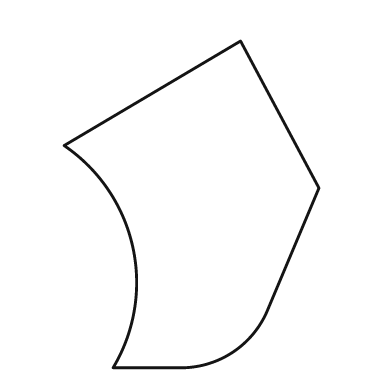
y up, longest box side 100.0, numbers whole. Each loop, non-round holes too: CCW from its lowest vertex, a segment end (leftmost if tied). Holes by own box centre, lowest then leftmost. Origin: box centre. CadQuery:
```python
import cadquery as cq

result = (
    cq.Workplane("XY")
    .moveTo(-24.0, -50.0)
    .lineTo(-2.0, -50.0)
    .threePointArc((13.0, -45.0), (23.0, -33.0))
    .lineTo(39.0, 5.0)
    .lineTo(15.0, 50.0)
    .lineTo(-39.0, 18.0)
    .threePointArc((-18.0, -13.0), (-24.0, -50.0))
    .close()
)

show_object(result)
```